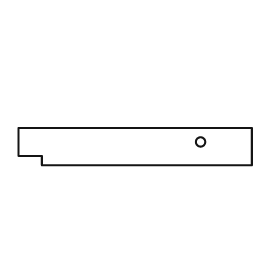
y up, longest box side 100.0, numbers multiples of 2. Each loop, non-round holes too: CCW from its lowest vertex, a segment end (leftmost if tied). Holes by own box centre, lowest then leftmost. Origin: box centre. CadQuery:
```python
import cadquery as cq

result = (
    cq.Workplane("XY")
    .moveTo(-40.0, -8.0)
    .lineTo(50.0, -8.0)
    .lineTo(50.0, 8.0)
    .lineTo(-50.0, 8.0)
    .lineTo(-50.0, -4.0)
    .lineTo(-40.0, -4.0)
    .close()
    .moveTo(28.0, 2.0)
    .circle(2.0)
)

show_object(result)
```